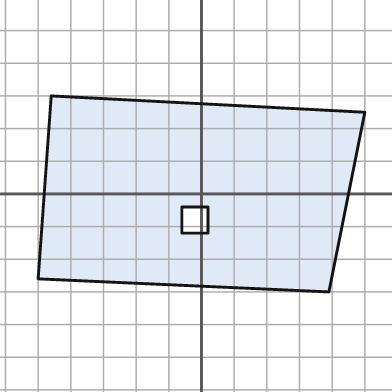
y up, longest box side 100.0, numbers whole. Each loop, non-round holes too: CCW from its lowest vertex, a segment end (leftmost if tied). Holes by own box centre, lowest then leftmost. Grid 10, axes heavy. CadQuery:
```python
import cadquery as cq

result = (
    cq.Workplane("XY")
    .moveTo(39.0, -30.0)
    .lineTo(50.0, 25.0)
    .lineTo(-46.0, 30.0)
    .lineTo(-50.0, -26.0)
    .close()
    .moveTo(-6.0, -12.0)
    .lineTo(2.0, -12.0)
    .lineTo(2.0, -4.0)
    .lineTo(-6.0, -4.0)
    .close()
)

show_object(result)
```